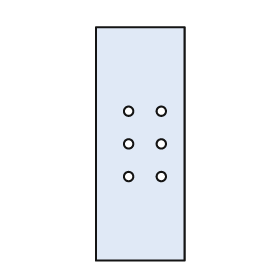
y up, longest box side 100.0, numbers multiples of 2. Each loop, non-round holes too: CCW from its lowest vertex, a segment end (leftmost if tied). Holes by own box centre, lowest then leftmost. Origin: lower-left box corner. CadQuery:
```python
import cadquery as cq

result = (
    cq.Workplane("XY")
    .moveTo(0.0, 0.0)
    .lineTo(38.0, 0.0)
    .lineTo(38.0, 100.0)
    .lineTo(0.0, 100.0)
    .close()
    .moveTo(14.0, 36.0)
    .circle(2.0)
    .moveTo(28.0, 36.0)
    .circle(2.0)
    .moveTo(14.0, 50.0)
    .circle(2.0)
    .moveTo(28.0, 50.0)
    .circle(2.0)
    .moveTo(14.0, 64.0)
    .circle(2.0)
    .moveTo(28.0, 64.0)
    .circle(2.0)
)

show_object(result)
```